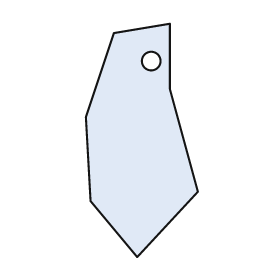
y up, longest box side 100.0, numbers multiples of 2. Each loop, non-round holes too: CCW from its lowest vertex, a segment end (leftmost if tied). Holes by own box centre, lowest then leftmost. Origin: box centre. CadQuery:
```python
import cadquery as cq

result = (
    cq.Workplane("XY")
    .moveTo(-2.0, -50.0)
    .lineTo(24.0, -22.0)
    .lineTo(12.0, 22.0)
    .lineTo(12.0, 50.0)
    .lineTo(-12.0, 46.0)
    .lineTo(-24.0, 10.0)
    .lineTo(-22.0, -26.0)
    .close()
    .moveTo(4.0, 34.0)
    .circle(4.0)
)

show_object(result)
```